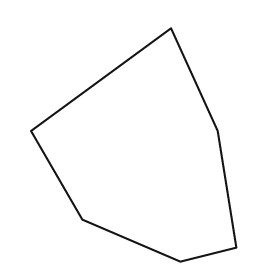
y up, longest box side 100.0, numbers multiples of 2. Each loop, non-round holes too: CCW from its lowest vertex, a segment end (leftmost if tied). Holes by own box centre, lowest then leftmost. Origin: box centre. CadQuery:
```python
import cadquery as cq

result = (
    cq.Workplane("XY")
    .moveTo(20.0, -50.0)
    .lineTo(44.0, -44.0)
    .lineTo(36.0, 6.0)
    .lineTo(16.0, 50.0)
    .lineTo(-44.0, 6.0)
    .lineTo(-22.0, -32.0)
    .close()
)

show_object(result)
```